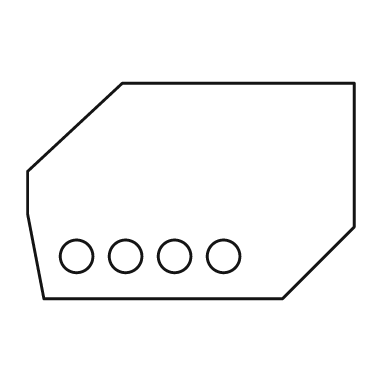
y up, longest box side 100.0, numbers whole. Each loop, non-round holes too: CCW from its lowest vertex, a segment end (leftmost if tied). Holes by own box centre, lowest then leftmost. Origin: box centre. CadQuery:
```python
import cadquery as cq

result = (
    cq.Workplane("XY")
    .moveTo(-45.0, -33.0)
    .lineTo(28.0, -33.0)
    .lineTo(50.0, -11.0)
    .lineTo(50.0, 33.0)
    .lineTo(-21.0, 33.0)
    .lineTo(-50.0, 6.0)
    .lineTo(-50.0, -7.0)
    .close()
    .moveTo(-35.0, -20.0)
    .circle(5.0)
    .moveTo(-20.0, -20.0)
    .circle(5.0)
    .moveTo(-5.0, -20.0)
    .circle(5.0)
    .moveTo(10.0, -20.0)
    .circle(5.0)
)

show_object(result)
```